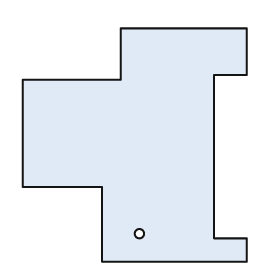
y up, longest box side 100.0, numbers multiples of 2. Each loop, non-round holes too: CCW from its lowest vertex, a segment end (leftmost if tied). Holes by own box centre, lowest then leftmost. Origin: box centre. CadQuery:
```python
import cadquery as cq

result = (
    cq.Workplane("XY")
    .moveTo(-14.0, -50.0)
    .lineTo(48.0, -50.0)
    .lineTo(48.0, -40.0)
    .lineTo(34.0, -40.0)
    .lineTo(34.0, 30.0)
    .lineTo(48.0, 30.0)
    .lineTo(48.0, 50.0)
    .lineTo(-6.0, 50.0)
    .lineTo(-6.0, 28.0)
    .lineTo(-48.0, 28.0)
    .lineTo(-48.0, -18.0)
    .lineTo(-14.0, -18.0)
    .close()
    .moveTo(2.0, -38.0)
    .circle(2.0)
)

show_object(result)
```